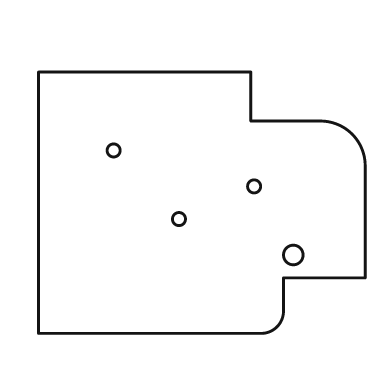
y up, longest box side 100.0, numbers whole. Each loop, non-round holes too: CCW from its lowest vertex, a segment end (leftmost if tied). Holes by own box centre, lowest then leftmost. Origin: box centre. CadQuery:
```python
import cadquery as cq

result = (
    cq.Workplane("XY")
    .moveTo(-50.0, -40.0)
    .lineTo(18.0, -40.0)
    .threePointArc((23.0, -38.0), (25.0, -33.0))
    .lineTo(25.0, -23.0)
    .lineTo(50.0, -23.0)
    .lineTo(50.0, 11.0)
    .threePointArc((46.0, 21.0), (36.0, 25.0))
    .lineTo(15.0, 25.0)
    .lineTo(15.0, 40.0)
    .lineTo(-50.0, 40.0)
    .close()
    .moveTo(28.0, -16.0)
    .circle(3.0)
    .moveTo(-7.0, -5.0)
    .circle(2.0)
    .moveTo(16.0, 5.0)
    .circle(2.0)
    .moveTo(-27.0, 16.0)
    .circle(2.0)
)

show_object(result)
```